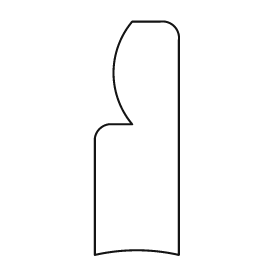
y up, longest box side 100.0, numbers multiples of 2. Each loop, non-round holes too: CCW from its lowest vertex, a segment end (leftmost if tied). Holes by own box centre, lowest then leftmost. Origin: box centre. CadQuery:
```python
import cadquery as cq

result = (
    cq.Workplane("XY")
    .moveTo(-18.0, -50.0)
    .threePointArc((0.0, -48.0), (18.0, -50.0))
    .lineTo(18.0, 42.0)
    .threePointArc((16.0, 48.0), (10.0, 50.0))
    .lineTo(-2.0, 50.0)
    .threePointArc((-10.0, 28.0), (-2.0, 6.0))
    .lineTo(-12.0, 6.0)
    .threePointArc((-16.0, 4.0), (-18.0, 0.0))
    .close()
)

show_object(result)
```